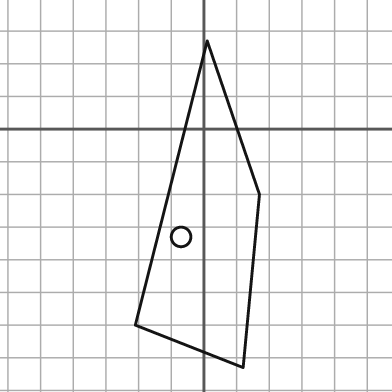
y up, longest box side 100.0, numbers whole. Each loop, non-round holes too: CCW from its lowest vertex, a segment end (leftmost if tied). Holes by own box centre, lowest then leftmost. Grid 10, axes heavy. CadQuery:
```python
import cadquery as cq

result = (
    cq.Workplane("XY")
    .moveTo(12.0, -73.0)
    .lineTo(17.0, -20.0)
    .lineTo(1.0, 27.0)
    .lineTo(-21.0, -60.0)
    .close()
    .moveTo(-7.0, -33.0)
    .circle(3.0)
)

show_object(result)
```